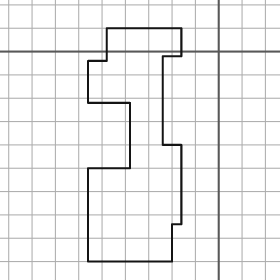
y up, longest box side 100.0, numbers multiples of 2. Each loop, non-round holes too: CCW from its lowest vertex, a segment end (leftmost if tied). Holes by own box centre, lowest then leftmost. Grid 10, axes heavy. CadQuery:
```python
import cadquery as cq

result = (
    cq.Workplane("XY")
    .moveTo(-56.0, -90.0)
    .lineTo(-20.0, -90.0)
    .lineTo(-20.0, -74.0)
    .lineTo(-16.0, -74.0)
    .lineTo(-16.0, -40.0)
    .lineTo(-24.0, -40.0)
    .lineTo(-24.0, -2.0)
    .lineTo(-16.0, -2.0)
    .lineTo(-16.0, 10.0)
    .lineTo(-48.0, 10.0)
    .lineTo(-48.0, -4.0)
    .lineTo(-56.0, -4.0)
    .lineTo(-56.0, -22.0)
    .lineTo(-38.0, -22.0)
    .lineTo(-38.0, -50.0)
    .lineTo(-56.0, -50.0)
    .close()
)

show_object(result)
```